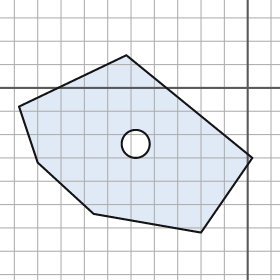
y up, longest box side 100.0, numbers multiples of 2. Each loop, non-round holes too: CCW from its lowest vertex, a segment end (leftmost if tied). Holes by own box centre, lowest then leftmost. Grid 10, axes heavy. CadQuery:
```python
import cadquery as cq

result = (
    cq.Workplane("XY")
    .moveTo(-20.0, -62.0)
    .lineTo(2.0, -30.0)
    .lineTo(-52.0, 14.0)
    .lineTo(-98.0, -8.0)
    .lineTo(-90.0, -32.0)
    .lineTo(-66.0, -54.0)
    .close()
    .moveTo(-48.0, -24.0)
    .circle(6.0)
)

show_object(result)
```